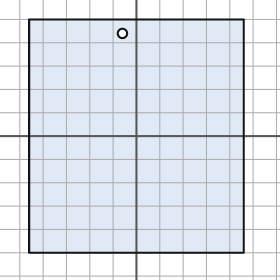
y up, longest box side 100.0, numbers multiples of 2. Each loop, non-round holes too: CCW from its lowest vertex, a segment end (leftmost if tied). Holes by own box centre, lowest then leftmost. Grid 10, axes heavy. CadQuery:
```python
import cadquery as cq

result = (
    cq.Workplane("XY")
    .moveTo(-46.0, -50.0)
    .lineTo(46.0, -50.0)
    .lineTo(46.0, 50.0)
    .lineTo(-46.0, 50.0)
    .close()
    .moveTo(-6.0, 44.0)
    .circle(2.0)
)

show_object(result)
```